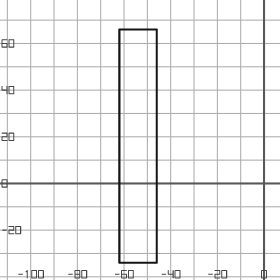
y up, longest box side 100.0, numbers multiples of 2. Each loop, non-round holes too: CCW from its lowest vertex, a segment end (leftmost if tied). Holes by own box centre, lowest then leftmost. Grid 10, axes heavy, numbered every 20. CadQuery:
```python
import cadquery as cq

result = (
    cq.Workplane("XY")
    .moveTo(-62.0, -34.0)
    .lineTo(-46.0, -34.0)
    .lineTo(-46.0, 66.0)
    .lineTo(-62.0, 66.0)
    .close()
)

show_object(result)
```